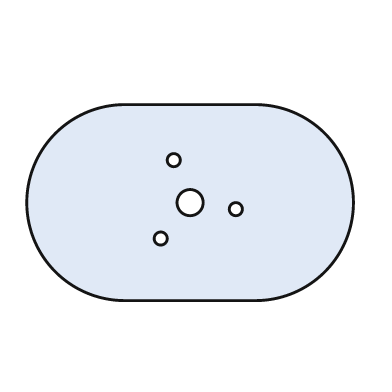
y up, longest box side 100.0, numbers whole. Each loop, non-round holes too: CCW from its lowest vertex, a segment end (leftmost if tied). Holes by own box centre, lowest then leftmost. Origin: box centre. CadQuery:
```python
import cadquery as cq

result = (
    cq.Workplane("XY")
    .moveTo(-20.0, -30.0)
    .lineTo(20.0, -30.0)
    .threePointArc((50.0, 0.0), (20.0, 30.0))
    .lineTo(-20.0, 30.0)
    .threePointArc((-50.0, 0.0), (-20.0, -30.0))
    .close()
    .moveTo(-9.0, -11.0)
    .circle(2.0)
    .moveTo(14.0, -2.0)
    .circle(2.0)
    .moveTo(0.0, 0.0)
    .circle(4.0)
    .moveTo(-5.0, 13.0)
    .circle(2.0)
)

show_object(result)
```